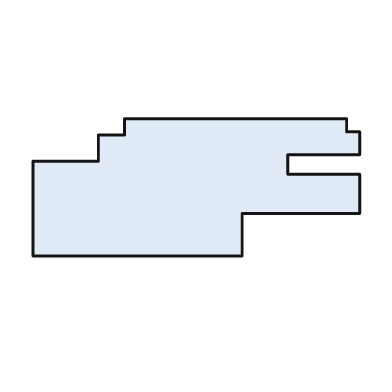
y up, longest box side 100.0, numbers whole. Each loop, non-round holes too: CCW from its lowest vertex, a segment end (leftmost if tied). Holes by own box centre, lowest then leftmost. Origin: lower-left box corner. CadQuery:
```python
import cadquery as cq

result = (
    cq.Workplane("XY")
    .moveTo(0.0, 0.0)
    .lineTo(64.0, 0.0)
    .lineTo(64.0, 13.0)
    .lineTo(100.0, 13.0)
    .lineTo(100.0, 25.0)
    .lineTo(78.0, 25.0)
    .lineTo(78.0, 31.0)
    .lineTo(100.0, 31.0)
    .lineTo(100.0, 38.0)
    .lineTo(96.0, 38.0)
    .lineTo(96.0, 42.0)
    .lineTo(28.0, 42.0)
    .lineTo(28.0, 37.0)
    .lineTo(20.0, 37.0)
    .lineTo(20.0, 29.0)
    .lineTo(0.0, 29.0)
    .close()
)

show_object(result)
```